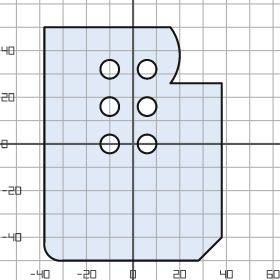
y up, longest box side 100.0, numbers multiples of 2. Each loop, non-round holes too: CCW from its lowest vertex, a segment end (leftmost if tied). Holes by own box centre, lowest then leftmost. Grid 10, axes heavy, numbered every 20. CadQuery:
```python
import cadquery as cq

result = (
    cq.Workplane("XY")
    .moveTo(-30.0, -50.0)
    .lineTo(28.0, -50.0)
    .lineTo(38.0, -40.0)
    .lineTo(38.0, 26.0)
    .lineTo(16.0, 26.0)
    .threePointArc((20.0, 38.0), (16.0, 50.0))
    .lineTo(-38.0, 50.0)
    .lineTo(-38.0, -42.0)
    .threePointArc((-36.0, -48.0), (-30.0, -50.0))
    .close()
    .moveTo(-10.0, 0.0)
    .circle(4.0)
    .moveTo(6.0, 0.0)
    .circle(4.0)
    .moveTo(-10.0, 16.0)
    .circle(4.0)
    .moveTo(6.0, 16.0)
    .circle(4.0)
    .moveTo(-10.0, 32.0)
    .circle(4.0)
    .moveTo(6.0, 32.0)
    .circle(4.0)
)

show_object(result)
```